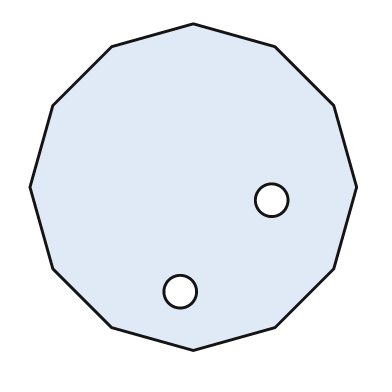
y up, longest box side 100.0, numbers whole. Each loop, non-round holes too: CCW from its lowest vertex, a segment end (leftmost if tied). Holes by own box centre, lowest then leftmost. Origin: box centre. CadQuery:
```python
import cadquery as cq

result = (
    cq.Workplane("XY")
    .moveTo(0.0, -50.0)
    .lineTo(25.0, -43.0)
    .lineTo(43.0, -25.0)
    .lineTo(50.0, 0.0)
    .lineTo(43.0, 25.0)
    .lineTo(25.0, 43.0)
    .lineTo(0.0, 50.0)
    .lineTo(-25.0, 43.0)
    .lineTo(-43.0, 25.0)
    .lineTo(-50.0, 0.0)
    .lineTo(-43.0, -25.0)
    .lineTo(-25.0, -43.0)
    .close()
    .moveTo(-4.0, -32.0)
    .circle(5.0)
    .moveTo(24.0, -4.0)
    .circle(5.0)
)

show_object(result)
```